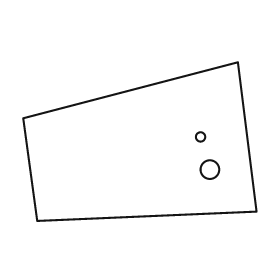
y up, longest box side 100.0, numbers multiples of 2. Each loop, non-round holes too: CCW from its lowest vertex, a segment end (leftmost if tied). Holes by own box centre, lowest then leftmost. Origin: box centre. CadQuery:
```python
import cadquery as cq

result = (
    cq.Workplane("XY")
    .moveTo(-44.0, -34.0)
    .lineTo(50.0, -30.0)
    .lineTo(42.0, 34.0)
    .lineTo(-50.0, 10.0)
    .close()
    .moveTo(30.0, -12.0)
    .circle(4.0)
    .moveTo(26.0, 2.0)
    .circle(2.0)
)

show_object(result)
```